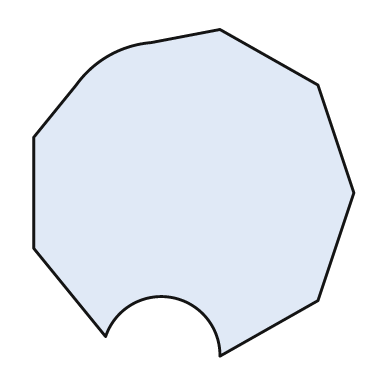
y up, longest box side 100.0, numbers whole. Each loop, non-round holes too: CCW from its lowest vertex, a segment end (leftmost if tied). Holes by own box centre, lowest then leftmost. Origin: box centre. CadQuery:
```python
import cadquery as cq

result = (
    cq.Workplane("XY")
    .moveTo(8.0, -50.0)
    .lineTo(38.0, -33.0)
    .lineTo(49.0, 0.0)
    .lineTo(38.0, 33.0)
    .lineTo(8.0, 50.0)
    .lineTo(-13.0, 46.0)
    .threePointArc((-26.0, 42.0), (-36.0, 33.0))
    .lineTo(-49.0, 17.0)
    .lineTo(-49.0, -17.0)
    .lineTo(-27.0, -44.0)
    .threePointArc((-7.0, -32.0), (8.0, -50.0))
    .close()
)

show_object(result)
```